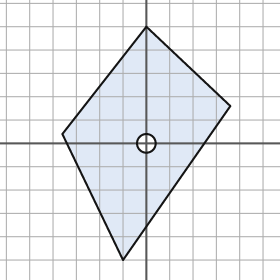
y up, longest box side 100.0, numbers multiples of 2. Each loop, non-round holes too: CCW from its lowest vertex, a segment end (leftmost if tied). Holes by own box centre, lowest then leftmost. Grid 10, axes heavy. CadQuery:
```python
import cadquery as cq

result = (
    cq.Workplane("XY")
    .moveTo(-10.0, -50.0)
    .lineTo(36.0, 16.0)
    .lineTo(0.0, 50.0)
    .lineTo(-36.0, 4.0)
    .close()
    .moveTo(0.0, 0.0)
    .circle(4.0)
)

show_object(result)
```